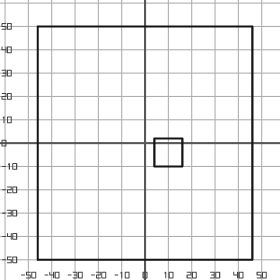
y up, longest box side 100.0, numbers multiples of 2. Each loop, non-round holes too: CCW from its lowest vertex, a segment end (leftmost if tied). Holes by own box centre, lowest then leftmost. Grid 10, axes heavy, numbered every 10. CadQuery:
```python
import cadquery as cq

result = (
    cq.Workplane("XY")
    .moveTo(-46.0, -50.0)
    .lineTo(46.0, -50.0)
    .lineTo(46.0, 50.0)
    .lineTo(-46.0, 50.0)
    .close()
    .moveTo(4.0, -10.0)
    .lineTo(16.0, -10.0)
    .lineTo(16.0, 2.0)
    .lineTo(4.0, 2.0)
    .close()
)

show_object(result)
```